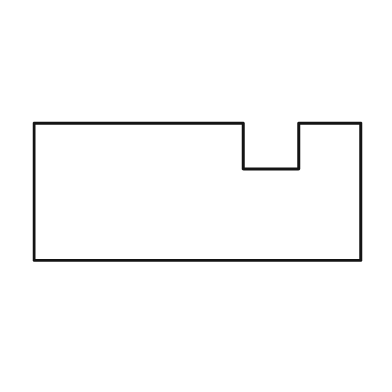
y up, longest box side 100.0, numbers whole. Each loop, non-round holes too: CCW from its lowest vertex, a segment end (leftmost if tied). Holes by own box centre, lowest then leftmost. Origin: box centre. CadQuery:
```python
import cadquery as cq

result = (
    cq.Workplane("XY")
    .moveTo(-50.0, -21.0)
    .lineTo(50.0, -21.0)
    .lineTo(50.0, 21.0)
    .lineTo(31.0, 21.0)
    .lineTo(31.0, 7.0)
    .lineTo(14.0, 7.0)
    .lineTo(14.0, 21.0)
    .lineTo(-50.0, 21.0)
    .close()
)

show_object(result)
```